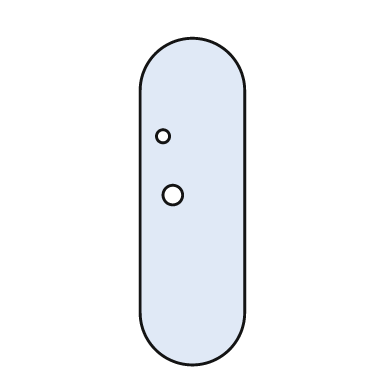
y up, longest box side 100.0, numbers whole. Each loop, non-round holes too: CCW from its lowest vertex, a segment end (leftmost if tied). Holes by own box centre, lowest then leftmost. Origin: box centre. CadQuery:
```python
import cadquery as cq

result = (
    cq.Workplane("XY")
    .moveTo(-16.0, -34.0)
    .threePointArc((0.0, -50.0), (16.0, -34.0))
    .lineTo(16.0, 34.0)
    .threePointArc((0.0, 50.0), (-16.0, 34.0))
    .close()
    .moveTo(-6.0, 2.0)
    .circle(3.0)
    .moveTo(-9.0, 20.0)
    .circle(2.0)
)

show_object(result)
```